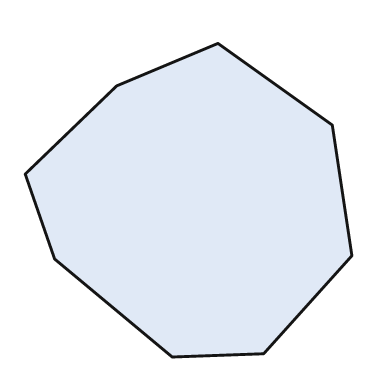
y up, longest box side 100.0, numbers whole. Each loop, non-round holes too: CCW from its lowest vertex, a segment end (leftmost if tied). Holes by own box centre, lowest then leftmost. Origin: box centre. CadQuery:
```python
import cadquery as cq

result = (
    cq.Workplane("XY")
    .moveTo(-5.0, -48.0)
    .lineTo(23.0, -47.0)
    .lineTo(50.0, -17.0)
    .lineTo(44.0, 23.0)
    .lineTo(9.0, 48.0)
    .lineTo(-22.0, 35.0)
    .lineTo(-50.0, 8.0)
    .lineTo(-41.0, -18.0)
    .close()
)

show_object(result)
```